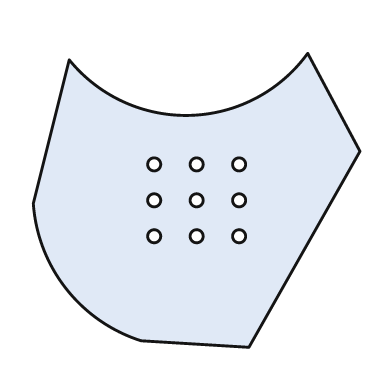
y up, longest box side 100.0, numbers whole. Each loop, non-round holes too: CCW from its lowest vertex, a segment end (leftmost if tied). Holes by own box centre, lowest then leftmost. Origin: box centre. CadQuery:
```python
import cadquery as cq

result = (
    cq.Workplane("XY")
    .moveTo(16.0, -45.0)
    .lineTo(50.0, 15.0)
    .lineTo(34.0, 45.0)
    .threePointArc((-2.0, 26.0), (-39.0, 43.0))
    .lineTo(-50.0, -1.0)
    .threePointArc((-40.0, -27.0), (-17.0, -43.0))
    .close()
    .moveTo(-13.0, -11.0)
    .circle(2.0)
    .moveTo(0.0, -11.0)
    .circle(2.0)
    .moveTo(13.0, -11.0)
    .circle(2.0)
    .moveTo(-13.0, 0.0)
    .circle(2.0)
    .moveTo(0.0, 0.0)
    .circle(2.0)
    .moveTo(13.0, 0.0)
    .circle(2.0)
    .moveTo(-13.0, 11.0)
    .circle(2.0)
    .moveTo(0.0, 11.0)
    .circle(2.0)
    .moveTo(13.0, 11.0)
    .circle(2.0)
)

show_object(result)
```